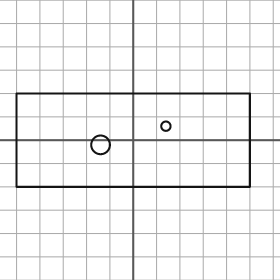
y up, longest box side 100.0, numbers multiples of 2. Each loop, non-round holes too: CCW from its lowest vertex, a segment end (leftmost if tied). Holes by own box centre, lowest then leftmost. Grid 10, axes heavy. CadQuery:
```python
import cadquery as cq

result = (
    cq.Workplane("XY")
    .moveTo(-50.0, -20.0)
    .lineTo(50.0, -20.0)
    .lineTo(50.0, 20.0)
    .lineTo(-50.0, 20.0)
    .close()
    .moveTo(-14.0, -2.0)
    .circle(4.0)
    .moveTo(14.0, 6.0)
    .circle(2.0)
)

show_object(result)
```